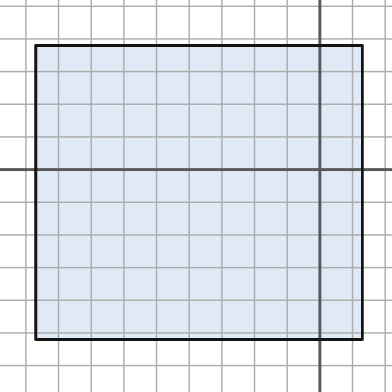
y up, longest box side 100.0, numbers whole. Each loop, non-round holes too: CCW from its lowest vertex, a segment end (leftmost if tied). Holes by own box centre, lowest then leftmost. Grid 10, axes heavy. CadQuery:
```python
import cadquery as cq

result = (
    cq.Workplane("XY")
    .moveTo(-87.0, -52.0)
    .lineTo(13.0, -52.0)
    .lineTo(13.0, 38.0)
    .lineTo(-87.0, 38.0)
    .close()
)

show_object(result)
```